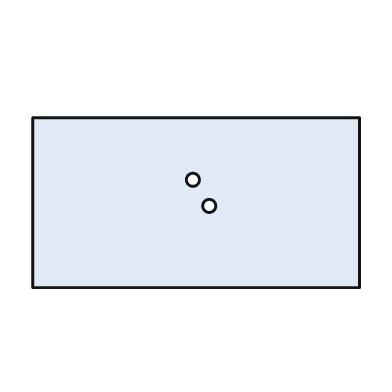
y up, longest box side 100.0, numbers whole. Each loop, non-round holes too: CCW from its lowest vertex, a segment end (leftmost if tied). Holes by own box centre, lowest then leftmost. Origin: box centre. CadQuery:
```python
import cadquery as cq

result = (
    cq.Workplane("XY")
    .moveTo(-50.0, -26.0)
    .lineTo(50.0, -26.0)
    .lineTo(50.0, 26.0)
    .lineTo(-50.0, 26.0)
    .close()
    .moveTo(4.0, -1.0)
    .circle(2.0)
    .moveTo(-1.0, 7.0)
    .circle(2.0)
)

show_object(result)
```